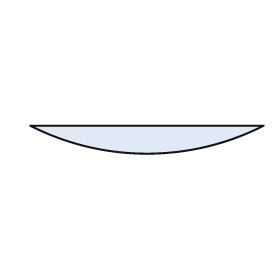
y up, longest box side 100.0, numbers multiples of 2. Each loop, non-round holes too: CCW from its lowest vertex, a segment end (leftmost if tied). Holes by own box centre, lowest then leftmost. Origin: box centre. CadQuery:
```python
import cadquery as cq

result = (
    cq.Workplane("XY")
    .moveTo(-50.0, 6.0)
    .threePointArc((0.0, -6.0), (50.0, 6.0))
    .close()
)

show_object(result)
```